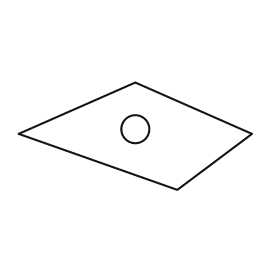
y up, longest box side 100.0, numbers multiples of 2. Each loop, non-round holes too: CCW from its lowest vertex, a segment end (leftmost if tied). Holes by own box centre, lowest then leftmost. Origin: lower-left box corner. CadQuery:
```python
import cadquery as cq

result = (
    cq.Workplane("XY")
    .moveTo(68.0, 0.0)
    .lineTo(100.0, 24.0)
    .lineTo(50.0, 46.0)
    .lineTo(0.0, 24.0)
    .close()
    .moveTo(50.0, 26.0)
    .circle(6.0)
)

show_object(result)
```